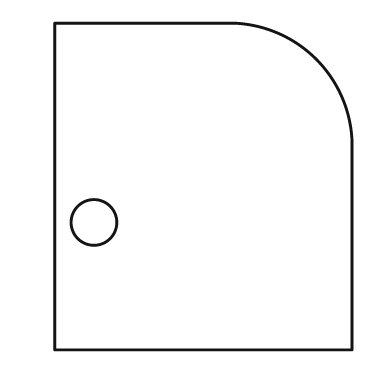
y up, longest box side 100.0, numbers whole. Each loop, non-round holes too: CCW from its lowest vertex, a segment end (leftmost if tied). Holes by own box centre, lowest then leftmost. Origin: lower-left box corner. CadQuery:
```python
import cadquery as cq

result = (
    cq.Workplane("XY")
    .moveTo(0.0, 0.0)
    .lineTo(91.0, 0.0)
    .lineTo(91.0, 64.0)
    .threePointArc((80.0, 89.0), (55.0, 100.0))
    .lineTo(0.0, 100.0)
    .close()
    .moveTo(12.0, 39.0)
    .circle(7.0)
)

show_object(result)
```